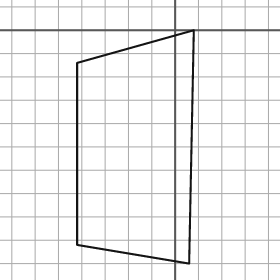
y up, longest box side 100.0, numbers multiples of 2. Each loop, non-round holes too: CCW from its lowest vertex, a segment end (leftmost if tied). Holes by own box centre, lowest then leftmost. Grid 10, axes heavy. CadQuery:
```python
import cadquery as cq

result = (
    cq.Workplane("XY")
    .moveTo(6.0, -100.0)
    .lineTo(8.0, 0.0)
    .lineTo(-42.0, -14.0)
    .lineTo(-42.0, -92.0)
    .close()
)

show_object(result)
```